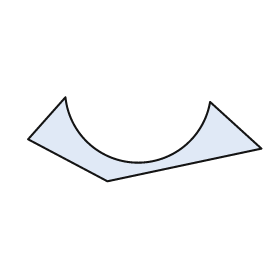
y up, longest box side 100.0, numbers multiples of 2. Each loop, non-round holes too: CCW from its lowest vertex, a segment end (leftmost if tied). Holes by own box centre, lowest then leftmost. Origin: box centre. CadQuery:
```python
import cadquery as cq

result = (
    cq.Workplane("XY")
    .moveTo(-16.0, -18.0)
    .lineTo(50.0, -4.0)
    .lineTo(28.0, 16.0)
    .threePointArc((-4.0, -10.0), (-34.0, 18.0))
    .lineTo(-50.0, 0.0)
    .close()
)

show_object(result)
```